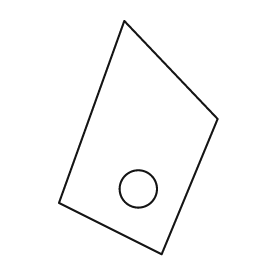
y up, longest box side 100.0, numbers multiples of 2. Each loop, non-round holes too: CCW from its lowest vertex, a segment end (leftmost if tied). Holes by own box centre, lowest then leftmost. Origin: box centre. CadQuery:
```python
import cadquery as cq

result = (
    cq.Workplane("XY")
    .moveTo(10.0, -50.0)
    .lineTo(34.0, 8.0)
    .lineTo(-6.0, 50.0)
    .lineTo(-34.0, -28.0)
    .close()
    .moveTo(0.0, -22.0)
    .circle(8.0)
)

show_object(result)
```